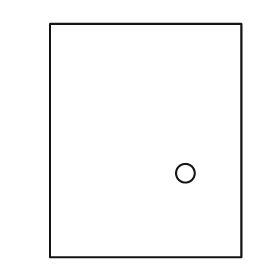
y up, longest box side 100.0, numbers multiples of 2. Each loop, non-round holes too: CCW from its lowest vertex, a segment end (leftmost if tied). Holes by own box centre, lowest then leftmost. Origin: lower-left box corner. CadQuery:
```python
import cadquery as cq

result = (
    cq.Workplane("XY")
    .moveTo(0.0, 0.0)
    .lineTo(82.0, 0.0)
    .lineTo(82.0, 100.0)
    .lineTo(0.0, 100.0)
    .close()
    .moveTo(58.0, 36.0)
    .circle(4.0)
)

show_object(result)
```